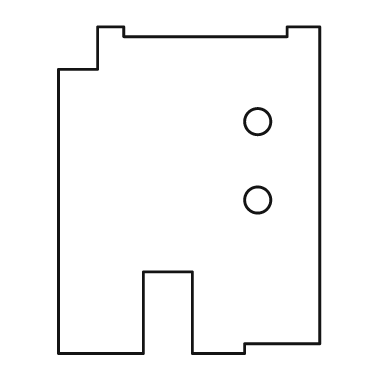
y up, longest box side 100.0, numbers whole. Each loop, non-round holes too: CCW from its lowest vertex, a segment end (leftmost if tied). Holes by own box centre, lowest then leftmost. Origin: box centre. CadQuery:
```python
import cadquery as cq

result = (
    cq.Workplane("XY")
    .moveTo(-40.0, -50.0)
    .lineTo(-14.0, -50.0)
    .lineTo(-14.0, -25.0)
    .lineTo(1.0, -25.0)
    .lineTo(1.0, -50.0)
    .lineTo(17.0, -50.0)
    .lineTo(17.0, -47.0)
    .lineTo(40.0, -47.0)
    .lineTo(40.0, 50.0)
    .lineTo(30.0, 50.0)
    .lineTo(30.0, 47.0)
    .lineTo(-20.0, 47.0)
    .lineTo(-20.0, 50.0)
    .lineTo(-28.0, 50.0)
    .lineTo(-28.0, 37.0)
    .lineTo(-40.0, 37.0)
    .close()
    .moveTo(21.0, -3.0)
    .circle(4.0)
    .moveTo(21.0, 21.0)
    .circle(4.0)
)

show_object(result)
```